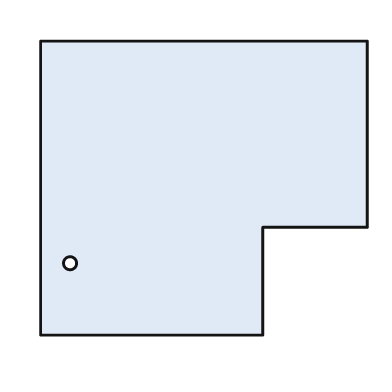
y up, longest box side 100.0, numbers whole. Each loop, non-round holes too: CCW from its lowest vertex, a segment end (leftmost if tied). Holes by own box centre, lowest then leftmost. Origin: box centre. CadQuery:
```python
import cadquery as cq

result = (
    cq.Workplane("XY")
    .moveTo(-50.0, -45.0)
    .lineTo(18.0, -45.0)
    .lineTo(18.0, -12.0)
    .lineTo(50.0, -12.0)
    .lineTo(50.0, 45.0)
    .lineTo(-50.0, 45.0)
    .close()
    .moveTo(-41.0, -23.0)
    .circle(2.0)
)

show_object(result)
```